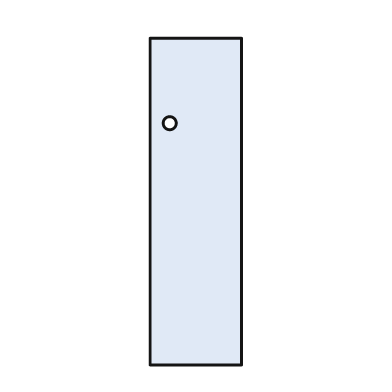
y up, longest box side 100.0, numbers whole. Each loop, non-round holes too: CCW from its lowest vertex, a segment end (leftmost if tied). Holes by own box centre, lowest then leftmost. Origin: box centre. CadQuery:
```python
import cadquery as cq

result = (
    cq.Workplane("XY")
    .moveTo(-14.0, -50.0)
    .lineTo(14.0, -50.0)
    .lineTo(14.0, 50.0)
    .lineTo(-14.0, 50.0)
    .close()
    .moveTo(-8.0, 24.0)
    .circle(2.0)
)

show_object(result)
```